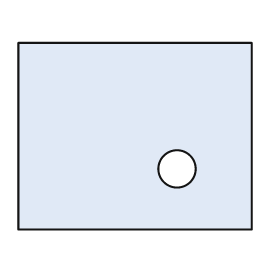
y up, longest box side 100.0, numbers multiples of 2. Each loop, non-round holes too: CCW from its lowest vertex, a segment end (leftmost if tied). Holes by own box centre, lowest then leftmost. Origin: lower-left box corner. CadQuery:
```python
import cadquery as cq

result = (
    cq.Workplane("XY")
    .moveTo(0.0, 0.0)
    .lineTo(100.0, 0.0)
    .lineTo(100.0, 80.0)
    .lineTo(0.0, 80.0)
    .close()
    .moveTo(68.0, 26.0)
    .circle(8.0)
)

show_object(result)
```